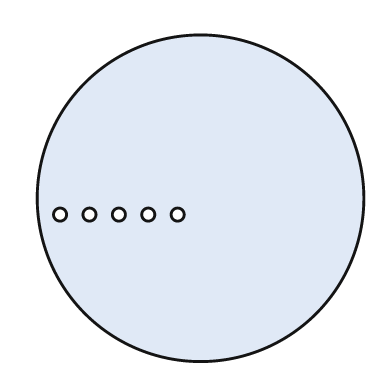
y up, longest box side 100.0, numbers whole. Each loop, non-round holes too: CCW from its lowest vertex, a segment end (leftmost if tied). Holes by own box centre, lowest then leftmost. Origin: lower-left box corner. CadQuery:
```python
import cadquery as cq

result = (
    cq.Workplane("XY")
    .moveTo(50.0, 50.0)
    .circle(50.0)
    .moveTo(7.0, 45.0)
    .circle(2.0)
    .moveTo(16.0, 45.0)
    .circle(2.0)
    .moveTo(25.0, 45.0)
    .circle(2.0)
    .moveTo(34.0, 45.0)
    .circle(2.0)
    .moveTo(43.0, 45.0)
    .circle(2.0)
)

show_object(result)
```